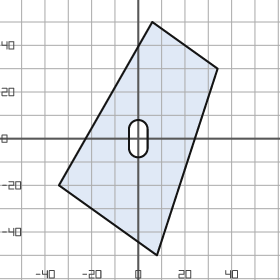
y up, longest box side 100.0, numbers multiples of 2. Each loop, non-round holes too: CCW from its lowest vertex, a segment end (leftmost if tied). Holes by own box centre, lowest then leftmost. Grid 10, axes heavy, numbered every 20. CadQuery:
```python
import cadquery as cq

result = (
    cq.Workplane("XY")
    .moveTo(8.0, -50.0)
    .lineTo(34.0, 30.0)
    .lineTo(6.0, 50.0)
    .lineTo(-34.0, -20.0)
    .close()
    .moveTo(-4.0, -4.0)
    .threePointArc((0.0, -8.0), (4.0, -4.0))
    .lineTo(4.0, 4.0)
    .threePointArc((0.0, 8.0), (-4.0, 4.0))
    .close()
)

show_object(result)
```